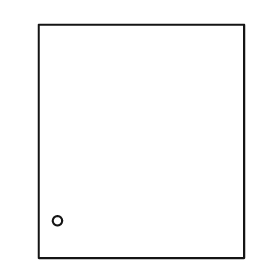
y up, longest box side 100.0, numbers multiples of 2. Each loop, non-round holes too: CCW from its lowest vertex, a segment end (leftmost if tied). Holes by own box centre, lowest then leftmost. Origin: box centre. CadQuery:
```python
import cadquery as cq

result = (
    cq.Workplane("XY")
    .moveTo(-44.0, -50.0)
    .lineTo(44.0, -50.0)
    .lineTo(44.0, 50.0)
    .lineTo(-44.0, 50.0)
    .close()
    .moveTo(-36.0, -34.0)
    .circle(2.0)
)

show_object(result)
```